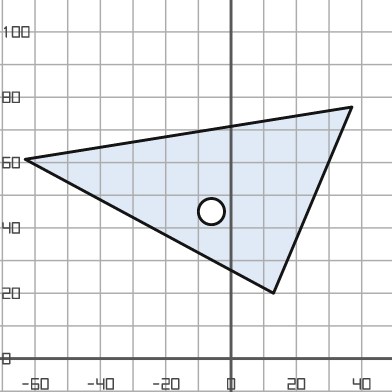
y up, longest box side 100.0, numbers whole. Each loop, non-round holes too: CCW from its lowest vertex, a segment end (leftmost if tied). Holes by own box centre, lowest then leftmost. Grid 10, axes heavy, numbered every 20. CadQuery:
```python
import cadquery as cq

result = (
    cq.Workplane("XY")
    .moveTo(13.0, 20.0)
    .lineTo(37.0, 77.0)
    .lineTo(-63.0, 61.0)
    .close()
    .moveTo(-6.0, 45.0)
    .circle(4.0)
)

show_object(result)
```